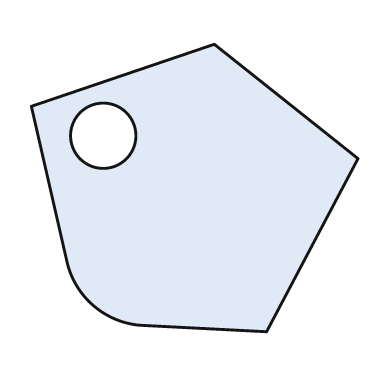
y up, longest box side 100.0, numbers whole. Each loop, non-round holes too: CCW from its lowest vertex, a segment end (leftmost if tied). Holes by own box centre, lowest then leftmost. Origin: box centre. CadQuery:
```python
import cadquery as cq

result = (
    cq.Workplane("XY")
    .moveTo(22.0, -44.0)
    .lineTo(50.0, 9.0)
    .lineTo(6.0, 44.0)
    .lineTo(-50.0, 25.0)
    .lineTo(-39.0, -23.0)
    .threePointArc((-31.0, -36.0), (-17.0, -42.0))
    .close()
    .moveTo(-28.0, 16.0)
    .circle(10.0)
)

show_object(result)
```